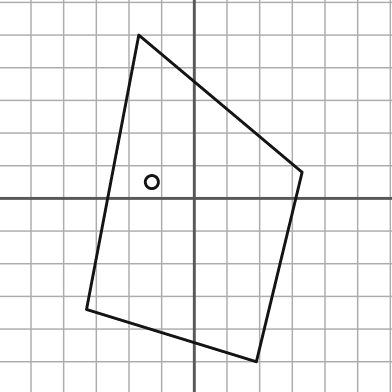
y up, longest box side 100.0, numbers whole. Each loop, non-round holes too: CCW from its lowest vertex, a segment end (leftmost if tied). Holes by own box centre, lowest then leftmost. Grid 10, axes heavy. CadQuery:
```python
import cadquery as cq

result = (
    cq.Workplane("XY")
    .moveTo(19.0, -50.0)
    .lineTo(33.0, 8.0)
    .lineTo(-17.0, 50.0)
    .lineTo(-33.0, -34.0)
    .close()
    .moveTo(-13.0, 5.0)
    .circle(2.0)
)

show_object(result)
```